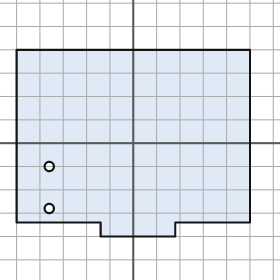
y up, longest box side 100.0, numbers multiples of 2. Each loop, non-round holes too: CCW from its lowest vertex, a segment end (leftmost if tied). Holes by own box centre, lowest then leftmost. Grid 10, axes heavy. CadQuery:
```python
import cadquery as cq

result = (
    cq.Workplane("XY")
    .moveTo(-14.0, -40.0)
    .lineTo(18.0, -40.0)
    .lineTo(18.0, -34.0)
    .lineTo(50.0, -34.0)
    .lineTo(50.0, 40.0)
    .lineTo(-50.0, 40.0)
    .lineTo(-50.0, -34.0)
    .lineTo(-14.0, -34.0)
    .close()
    .moveTo(-36.0, -28.0)
    .circle(2.0)
    .moveTo(-36.0, -10.0)
    .circle(2.0)
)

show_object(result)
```